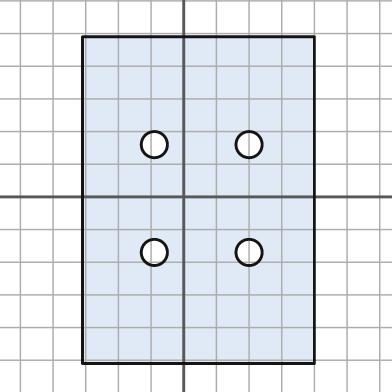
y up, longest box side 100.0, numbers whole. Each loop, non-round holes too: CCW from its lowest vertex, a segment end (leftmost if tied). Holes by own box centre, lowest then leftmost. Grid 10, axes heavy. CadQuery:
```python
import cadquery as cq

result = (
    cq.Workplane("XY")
    .moveTo(-31.0, -51.0)
    .lineTo(40.0, -51.0)
    .lineTo(40.0, 49.0)
    .lineTo(-31.0, 49.0)
    .close()
    .moveTo(-9.0, -17.0)
    .circle(4.0)
    .moveTo(20.0, -17.0)
    .circle(4.0)
    .moveTo(-9.0, 16.0)
    .circle(4.0)
    .moveTo(20.0, 16.0)
    .circle(4.0)
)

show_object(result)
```